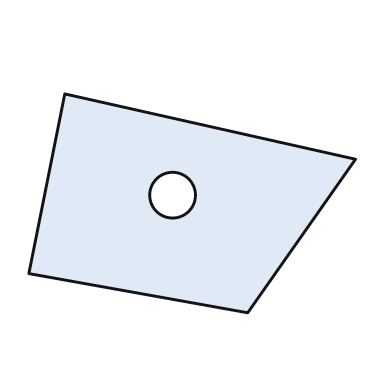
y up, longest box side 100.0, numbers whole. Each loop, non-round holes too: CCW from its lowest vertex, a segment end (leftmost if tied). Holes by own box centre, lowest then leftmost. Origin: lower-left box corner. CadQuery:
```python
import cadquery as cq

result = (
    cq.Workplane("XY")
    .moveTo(67.0, 0.0)
    .lineTo(100.0, 47.0)
    .lineTo(11.0, 67.0)
    .lineTo(0.0, 12.0)
    .close()
    .moveTo(44.0, 36.0)
    .circle(7.0)
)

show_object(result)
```